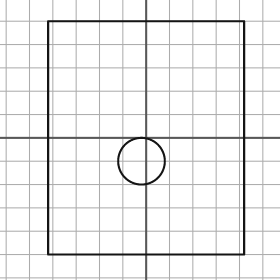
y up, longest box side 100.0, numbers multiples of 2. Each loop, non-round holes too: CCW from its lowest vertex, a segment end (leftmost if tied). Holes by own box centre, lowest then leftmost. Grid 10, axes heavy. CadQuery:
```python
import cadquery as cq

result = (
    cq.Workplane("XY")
    .moveTo(-42.0, -50.0)
    .lineTo(42.0, -50.0)
    .lineTo(42.0, 50.0)
    .lineTo(-42.0, 50.0)
    .close()
    .moveTo(-2.0, -10.0)
    .circle(10.0)
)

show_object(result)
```